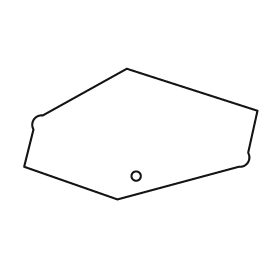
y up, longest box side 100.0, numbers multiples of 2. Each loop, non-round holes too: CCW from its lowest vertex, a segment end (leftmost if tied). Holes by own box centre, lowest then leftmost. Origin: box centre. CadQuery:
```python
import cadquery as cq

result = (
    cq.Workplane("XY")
    .moveTo(-10.0, -28.0)
    .lineTo(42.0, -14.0)
    .threePointArc((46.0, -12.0), (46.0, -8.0))
    .lineTo(50.0, 10.0)
    .lineTo(-6.0, 28.0)
    .lineTo(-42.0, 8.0)
    .threePointArc((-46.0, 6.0), (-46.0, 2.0))
    .lineTo(-50.0, -14.0)
    .close()
    .moveTo(-2.0, -18.0)
    .circle(2.0)
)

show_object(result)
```